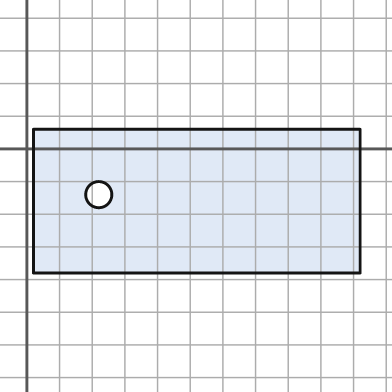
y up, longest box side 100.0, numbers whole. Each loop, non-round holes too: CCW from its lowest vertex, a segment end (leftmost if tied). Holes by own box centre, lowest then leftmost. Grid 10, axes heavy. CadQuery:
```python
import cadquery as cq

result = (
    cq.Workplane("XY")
    .moveTo(2.0, -38.0)
    .lineTo(102.0, -38.0)
    .lineTo(102.0, 6.0)
    .lineTo(2.0, 6.0)
    .close()
    .moveTo(22.0, -14.0)
    .circle(4.0)
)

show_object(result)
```